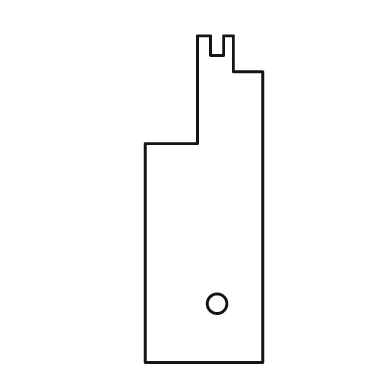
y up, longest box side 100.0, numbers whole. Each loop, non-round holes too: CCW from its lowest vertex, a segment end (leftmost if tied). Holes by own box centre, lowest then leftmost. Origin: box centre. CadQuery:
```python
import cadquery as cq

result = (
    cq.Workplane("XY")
    .moveTo(-18.0, -50.0)
    .lineTo(18.0, -50.0)
    .lineTo(18.0, 39.0)
    .lineTo(9.0, 39.0)
    .lineTo(9.0, 50.0)
    .lineTo(6.0, 50.0)
    .lineTo(6.0, 44.0)
    .lineTo(2.0, 44.0)
    .lineTo(2.0, 50.0)
    .lineTo(-2.0, 50.0)
    .lineTo(-2.0, 17.0)
    .lineTo(-18.0, 17.0)
    .close()
    .moveTo(4.0, -32.0)
    .circle(3.0)
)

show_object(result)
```